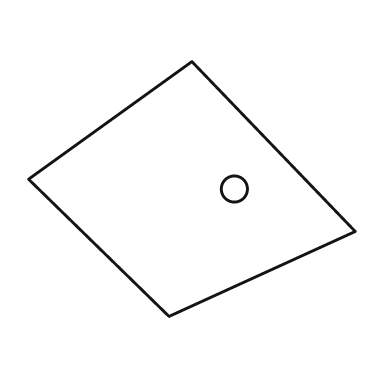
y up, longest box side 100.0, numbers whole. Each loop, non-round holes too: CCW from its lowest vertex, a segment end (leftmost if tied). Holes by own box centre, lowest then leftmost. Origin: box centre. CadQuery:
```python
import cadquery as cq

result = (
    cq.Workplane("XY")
    .moveTo(-7.0, -39.0)
    .lineTo(50.0, -13.0)
    .lineTo(0.0, 39.0)
    .lineTo(-50.0, 3.0)
    .close()
    .moveTo(13.0, 0.0)
    .circle(4.0)
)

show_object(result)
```